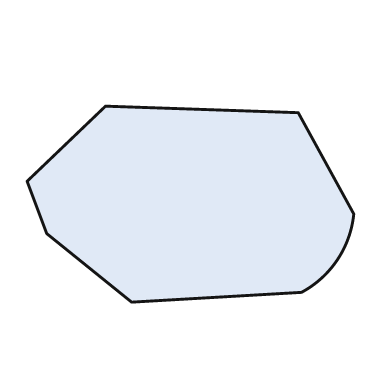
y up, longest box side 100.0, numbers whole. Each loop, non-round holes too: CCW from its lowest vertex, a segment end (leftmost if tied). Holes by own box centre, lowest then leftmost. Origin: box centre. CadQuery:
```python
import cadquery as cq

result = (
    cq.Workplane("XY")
    .moveTo(-18.0, -30.0)
    .lineTo(34.0, -27.0)
    .threePointArc((45.0, -17.0), (50.0, -3.0))
    .lineTo(33.0, 28.0)
    .lineTo(-26.0, 30.0)
    .lineTo(-50.0, 7.0)
    .lineTo(-44.0, -9.0)
    .close()
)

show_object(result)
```